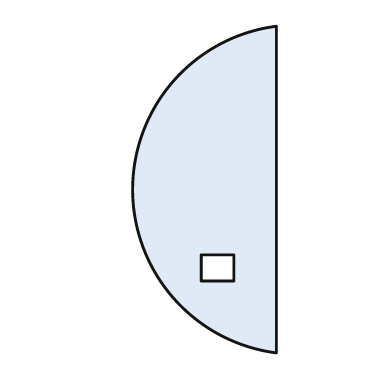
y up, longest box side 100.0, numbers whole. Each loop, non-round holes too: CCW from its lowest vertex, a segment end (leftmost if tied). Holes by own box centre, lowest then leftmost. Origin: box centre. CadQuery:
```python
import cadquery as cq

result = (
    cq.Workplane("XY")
    .moveTo(22.0, -50.0)
    .lineTo(22.0, 50.0)
    .threePointArc((-22.0, 0.0), (22.0, -50.0))
    .close()
    .moveTo(-1.0, -28.0)
    .lineTo(9.0, -28.0)
    .lineTo(9.0, -20.0)
    .lineTo(-1.0, -20.0)
    .close()
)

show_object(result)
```